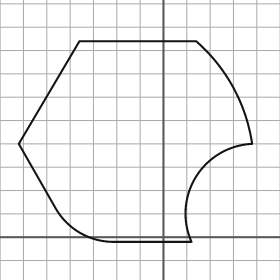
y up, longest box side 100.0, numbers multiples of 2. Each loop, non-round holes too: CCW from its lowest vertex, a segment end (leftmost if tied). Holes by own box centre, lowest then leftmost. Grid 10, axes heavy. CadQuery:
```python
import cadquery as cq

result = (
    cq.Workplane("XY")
    .moveTo(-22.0, -2.0)
    .lineTo(12.0, -2.0)
    .threePointArc((14.0, 26.0), (38.0, 40.0))
    .threePointArc((30.0, 64.0), (14.0, 84.0))
    .lineTo(-36.0, 84.0)
    .lineTo(-62.0, 40.0)
    .lineTo(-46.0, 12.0)
    .threePointArc((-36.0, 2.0), (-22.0, -2.0))
    .close()
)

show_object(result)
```